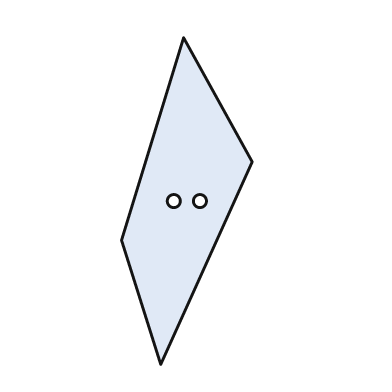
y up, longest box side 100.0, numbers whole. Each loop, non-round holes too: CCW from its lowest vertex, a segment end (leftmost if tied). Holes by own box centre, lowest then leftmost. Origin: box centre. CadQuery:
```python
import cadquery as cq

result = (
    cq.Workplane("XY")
    .moveTo(-8.0, -50.0)
    .lineTo(20.0, 12.0)
    .lineTo(-1.0, 50.0)
    .lineTo(-20.0, -12.0)
    .close()
    .moveTo(-4.0, 0.0)
    .circle(2.0)
    .moveTo(4.0, 0.0)
    .circle(2.0)
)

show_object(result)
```